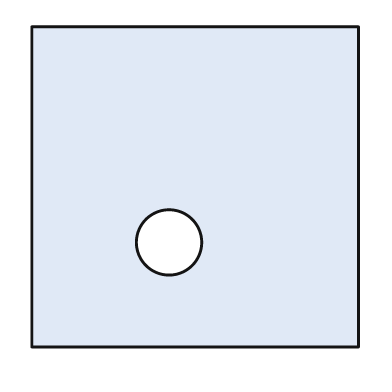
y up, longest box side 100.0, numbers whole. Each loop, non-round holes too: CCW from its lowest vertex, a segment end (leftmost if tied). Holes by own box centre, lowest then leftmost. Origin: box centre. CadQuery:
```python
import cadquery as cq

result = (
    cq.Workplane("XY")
    .moveTo(-50.0, -49.0)
    .lineTo(50.0, -49.0)
    .lineTo(50.0, 49.0)
    .lineTo(-50.0, 49.0)
    .close()
    .moveTo(-8.0, -17.0)
    .circle(10.0)
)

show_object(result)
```